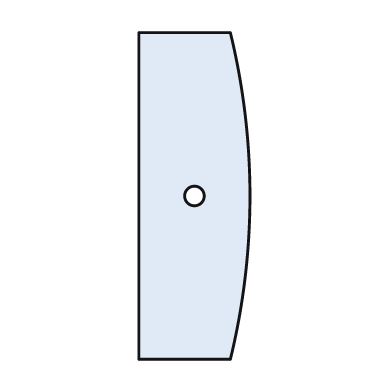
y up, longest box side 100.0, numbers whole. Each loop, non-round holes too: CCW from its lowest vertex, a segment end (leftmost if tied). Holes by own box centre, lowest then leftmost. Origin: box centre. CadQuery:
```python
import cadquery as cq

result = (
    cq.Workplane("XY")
    .moveTo(-17.0, -50.0)
    .lineTo(11.0, -50.0)
    .threePointArc((17.0, 0.0), (11.0, 50.0))
    .lineTo(-17.0, 50.0)
    .close()
    .moveTo(0.0, 0.0)
    .circle(3.0)
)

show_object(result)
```